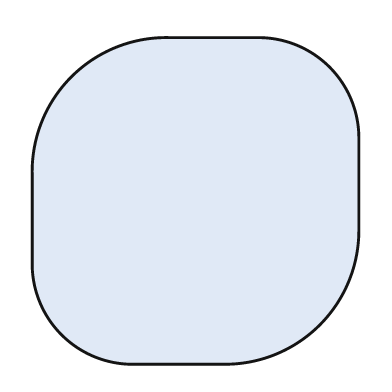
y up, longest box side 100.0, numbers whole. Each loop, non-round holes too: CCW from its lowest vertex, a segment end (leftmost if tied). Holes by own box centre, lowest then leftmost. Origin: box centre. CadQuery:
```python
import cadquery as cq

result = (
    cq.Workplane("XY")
    .moveTo(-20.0, -50.0)
    .lineTo(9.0, -50.0)
    .threePointArc((38.0, -38.0), (50.0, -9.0))
    .lineTo(50.0, 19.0)
    .threePointArc((41.0, 41.0), (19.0, 50.0))
    .lineTo(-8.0, 50.0)
    .threePointArc((-38.0, 38.0), (-50.0, 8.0))
    .lineTo(-50.0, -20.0)
    .threePointArc((-41.0, -41.0), (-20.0, -50.0))
    .close()
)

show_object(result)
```